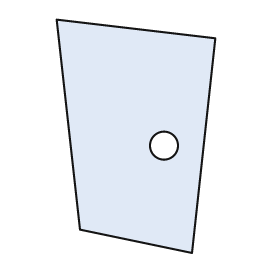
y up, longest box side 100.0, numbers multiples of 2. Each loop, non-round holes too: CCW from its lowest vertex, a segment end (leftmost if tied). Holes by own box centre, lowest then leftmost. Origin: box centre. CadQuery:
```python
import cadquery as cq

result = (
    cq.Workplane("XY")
    .moveTo(24.0, -50.0)
    .lineTo(34.0, 42.0)
    .lineTo(-34.0, 50.0)
    .lineTo(-24.0, -40.0)
    .close()
    .moveTo(12.0, -4.0)
    .circle(6.0)
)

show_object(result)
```